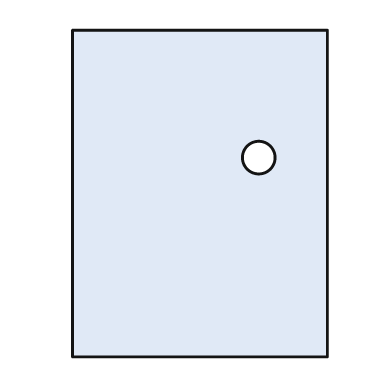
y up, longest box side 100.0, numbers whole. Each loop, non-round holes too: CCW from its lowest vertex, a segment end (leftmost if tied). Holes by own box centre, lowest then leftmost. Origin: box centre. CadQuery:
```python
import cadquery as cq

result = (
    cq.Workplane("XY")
    .moveTo(-39.0, -50.0)
    .lineTo(39.0, -50.0)
    .lineTo(39.0, 50.0)
    .lineTo(-39.0, 50.0)
    .close()
    .moveTo(18.0, 11.0)
    .circle(5.0)
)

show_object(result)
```